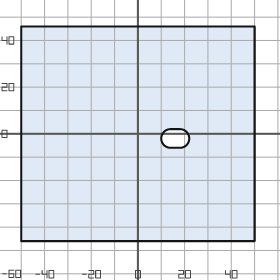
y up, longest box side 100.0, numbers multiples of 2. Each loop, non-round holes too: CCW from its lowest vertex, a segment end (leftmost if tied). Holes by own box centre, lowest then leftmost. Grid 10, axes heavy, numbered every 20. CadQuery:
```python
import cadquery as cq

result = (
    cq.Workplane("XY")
    .moveTo(-50.0, -46.0)
    .lineTo(50.0, -46.0)
    .lineTo(50.0, 46.0)
    .lineTo(-50.0, 46.0)
    .close()
    .moveTo(14.0, -6.0)
    .lineTo(18.0, -6.0)
    .threePointArc((22.0, -2.0), (18.0, 2.0))
    .lineTo(14.0, 2.0)
    .threePointArc((10.0, -2.0), (14.0, -6.0))
    .close()
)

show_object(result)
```